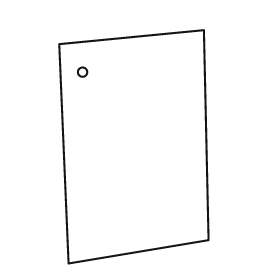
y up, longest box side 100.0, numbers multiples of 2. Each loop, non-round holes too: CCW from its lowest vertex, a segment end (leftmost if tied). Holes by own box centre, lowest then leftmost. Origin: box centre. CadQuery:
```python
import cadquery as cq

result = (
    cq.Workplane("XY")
    .moveTo(-28.0, -50.0)
    .lineTo(32.0, -40.0)
    .lineTo(30.0, 50.0)
    .lineTo(-32.0, 44.0)
    .close()
    .moveTo(-22.0, 32.0)
    .circle(2.0)
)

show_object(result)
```